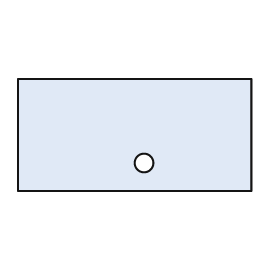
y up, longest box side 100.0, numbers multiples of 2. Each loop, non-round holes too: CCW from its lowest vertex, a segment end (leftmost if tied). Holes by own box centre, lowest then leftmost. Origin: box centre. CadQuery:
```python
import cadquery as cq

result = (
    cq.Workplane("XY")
    .moveTo(-50.0, -24.0)
    .lineTo(50.0, -24.0)
    .lineTo(50.0, 24.0)
    .lineTo(-50.0, 24.0)
    .close()
    .moveTo(4.0, -12.0)
    .circle(4.0)
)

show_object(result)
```